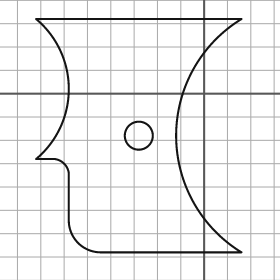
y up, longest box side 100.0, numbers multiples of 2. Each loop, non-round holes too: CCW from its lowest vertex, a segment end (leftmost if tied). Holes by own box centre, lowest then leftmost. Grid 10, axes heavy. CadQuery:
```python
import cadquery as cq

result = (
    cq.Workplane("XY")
    .moveTo(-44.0, -68.0)
    .lineTo(16.0, -68.0)
    .threePointArc((-12.0, -18.0), (16.0, 32.0))
    .lineTo(-72.0, 32.0)
    .threePointArc((-58.0, 2.0), (-72.0, -28.0))
    .lineTo(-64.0, -28.0)
    .threePointArc((-60.0, -30.0), (-58.0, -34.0))
    .lineTo(-58.0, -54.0)
    .threePointArc((-54.0, -64.0), (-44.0, -68.0))
    .close()
    .moveTo(-28.0, -18.0)
    .circle(6.0)
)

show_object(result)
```